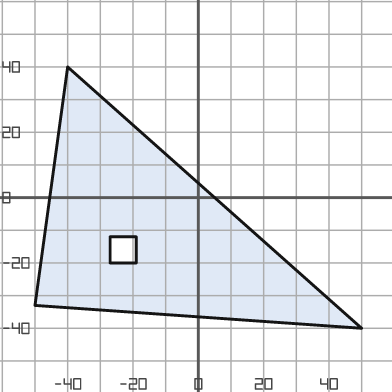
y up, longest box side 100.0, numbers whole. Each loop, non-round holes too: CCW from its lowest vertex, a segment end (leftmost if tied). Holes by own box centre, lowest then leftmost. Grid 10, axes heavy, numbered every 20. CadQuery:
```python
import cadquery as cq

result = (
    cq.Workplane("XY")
    .moveTo(50.0, -40.0)
    .lineTo(-40.0, 40.0)
    .lineTo(-50.0, -33.0)
    .close()
    .moveTo(-27.0, -20.0)
    .lineTo(-19.0, -20.0)
    .lineTo(-19.0, -12.0)
    .lineTo(-27.0, -12.0)
    .close()
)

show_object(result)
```